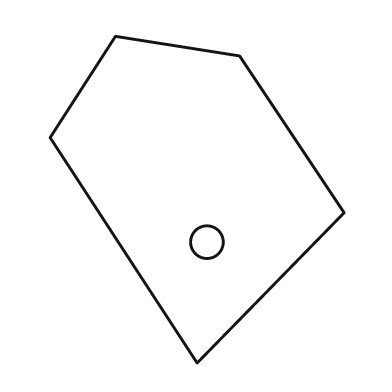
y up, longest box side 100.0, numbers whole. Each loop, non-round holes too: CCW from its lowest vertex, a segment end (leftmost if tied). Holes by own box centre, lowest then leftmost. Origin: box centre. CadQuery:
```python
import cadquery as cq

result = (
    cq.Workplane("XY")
    .moveTo(0.0, -50.0)
    .lineTo(45.0, -4.0)
    .lineTo(13.0, 44.0)
    .lineTo(-25.0, 50.0)
    .lineTo(-45.0, 19.0)
    .close()
    .moveTo(3.0, -13.0)
    .circle(5.0)
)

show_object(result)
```